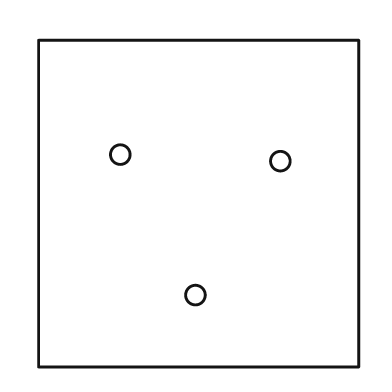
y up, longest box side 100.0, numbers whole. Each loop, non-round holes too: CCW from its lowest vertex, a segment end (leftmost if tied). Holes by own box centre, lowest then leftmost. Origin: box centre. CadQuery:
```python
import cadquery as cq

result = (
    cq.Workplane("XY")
    .moveTo(-49.0, -50.0)
    .lineTo(49.0, -50.0)
    .lineTo(49.0, 50.0)
    .lineTo(-49.0, 50.0)
    .close()
    .moveTo(-1.0, -28.0)
    .circle(3.0)
    .moveTo(25.0, 13.0)
    .circle(3.0)
    .moveTo(-24.0, 15.0)
    .circle(3.0)
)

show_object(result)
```